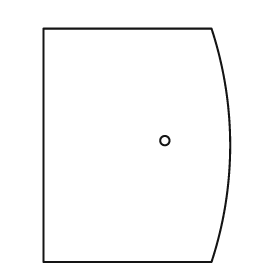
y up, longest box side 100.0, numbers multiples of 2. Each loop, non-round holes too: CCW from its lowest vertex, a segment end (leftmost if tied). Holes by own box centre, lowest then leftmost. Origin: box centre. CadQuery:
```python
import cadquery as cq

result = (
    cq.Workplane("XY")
    .moveTo(-40.0, -50.0)
    .lineTo(32.0, -50.0)
    .threePointArc((40.0, 0.0), (32.0, 50.0))
    .lineTo(-40.0, 50.0)
    .close()
    .moveTo(12.0, 2.0)
    .circle(2.0)
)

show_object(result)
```